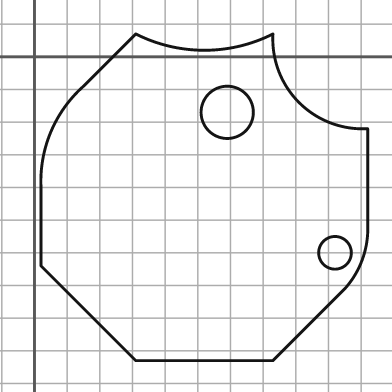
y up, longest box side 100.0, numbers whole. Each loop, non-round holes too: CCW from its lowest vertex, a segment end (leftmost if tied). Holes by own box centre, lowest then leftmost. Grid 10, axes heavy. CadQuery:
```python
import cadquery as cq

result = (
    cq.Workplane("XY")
    .moveTo(31.0, -93.0)
    .lineTo(73.0, -93.0)
    .lineTo(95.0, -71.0)
    .threePointArc((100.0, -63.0), (102.0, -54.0))
    .lineTo(102.0, -22.0)
    .threePointArc((81.0, -14.0), (73.0, 7.0))
    .threePointArc((52.0, 2.0), (31.0, 7.0))
    .lineTo(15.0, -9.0)
    .threePointArc((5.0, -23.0), (2.0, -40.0))
    .lineTo(2.0, -64.0)
    .close()
    .moveTo(92.0, -60.0)
    .circle(5.0)
    .moveTo(59.0, -17.0)
    .circle(8.0)
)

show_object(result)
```